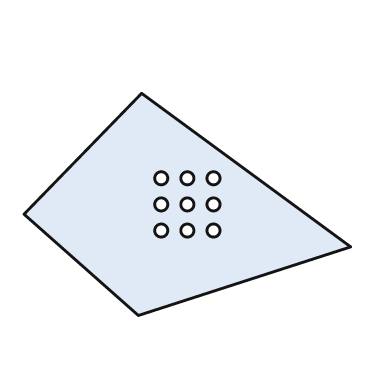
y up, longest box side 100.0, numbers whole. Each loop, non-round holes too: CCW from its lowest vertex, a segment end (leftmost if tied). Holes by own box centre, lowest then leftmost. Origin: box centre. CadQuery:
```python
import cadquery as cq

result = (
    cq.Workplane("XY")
    .moveTo(-15.0, -34.0)
    .lineTo(50.0, -13.0)
    .lineTo(-14.0, 34.0)
    .lineTo(-50.0, -3.0)
    .close()
    .moveTo(-8.0, -8.0)
    .circle(2.0)
    .moveTo(0.0, -8.0)
    .circle(2.0)
    .moveTo(8.0, -8.0)
    .circle(2.0)
    .moveTo(-8.0, 0.0)
    .circle(2.0)
    .moveTo(0.0, 0.0)
    .circle(2.0)
    .moveTo(8.0, 0.0)
    .circle(2.0)
    .moveTo(-8.0, 8.0)
    .circle(2.0)
    .moveTo(0.0, 8.0)
    .circle(2.0)
    .moveTo(8.0, 8.0)
    .circle(2.0)
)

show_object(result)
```